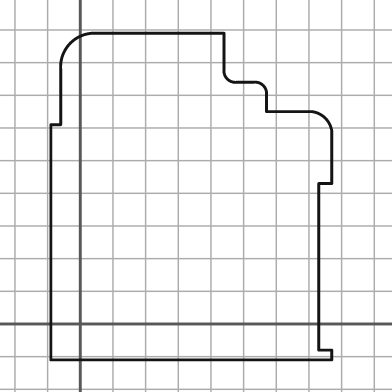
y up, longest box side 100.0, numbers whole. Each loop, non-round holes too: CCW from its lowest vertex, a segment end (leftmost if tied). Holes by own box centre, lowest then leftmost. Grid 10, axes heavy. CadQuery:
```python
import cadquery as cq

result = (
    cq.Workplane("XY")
    .moveTo(-9.0, -11.0)
    .lineTo(77.0, -11.0)
    .lineTo(77.0, -8.0)
    .lineTo(73.0, -8.0)
    .lineTo(73.0, 43.0)
    .lineTo(77.0, 43.0)
    .lineTo(77.0, 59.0)
    .threePointArc((75.0, 63.0), (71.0, 65.0))
    .lineTo(57.0, 65.0)
    .lineTo(57.0, 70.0)
    .threePointArc((56.0, 73.0), (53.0, 74.0))
    .lineTo(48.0, 74.0)
    .threePointArc((45.0, 75.0), (44.0, 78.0))
    .lineTo(44.0, 89.0)
    .lineTo(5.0, 89.0)
    .threePointArc((-3.0, 86.0), (-6.0, 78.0))
    .lineTo(-6.0, 61.0)
    .lineTo(-9.0, 61.0)
    .close()
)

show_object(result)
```